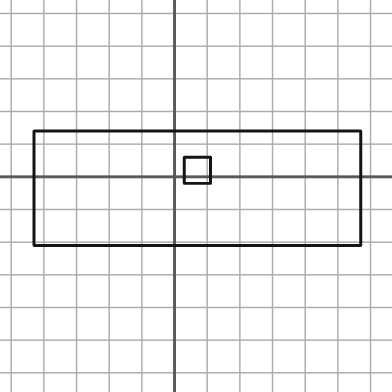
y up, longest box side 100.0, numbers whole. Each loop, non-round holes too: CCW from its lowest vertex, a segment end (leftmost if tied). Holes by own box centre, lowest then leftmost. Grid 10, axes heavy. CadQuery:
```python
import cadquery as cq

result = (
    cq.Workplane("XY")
    .moveTo(-43.0, -21.0)
    .lineTo(57.0, -21.0)
    .lineTo(57.0, 14.0)
    .lineTo(-43.0, 14.0)
    .close()
    .moveTo(3.0, -2.0)
    .lineTo(11.0, -2.0)
    .lineTo(11.0, 6.0)
    .lineTo(3.0, 6.0)
    .close()
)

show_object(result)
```